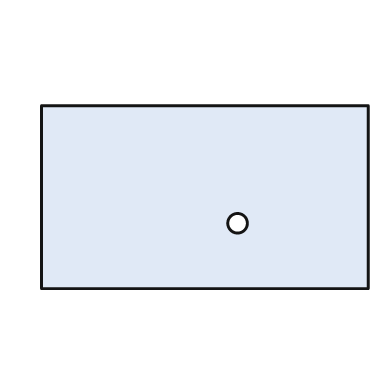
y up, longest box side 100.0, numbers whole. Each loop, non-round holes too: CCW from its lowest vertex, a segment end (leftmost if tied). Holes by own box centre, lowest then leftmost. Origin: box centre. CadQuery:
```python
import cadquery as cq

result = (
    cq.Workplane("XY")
    .moveTo(-50.0, -28.0)
    .lineTo(50.0, -28.0)
    .lineTo(50.0, 28.0)
    .lineTo(-50.0, 28.0)
    .close()
    .moveTo(10.0, -8.0)
    .circle(3.0)
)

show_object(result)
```